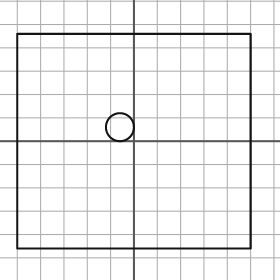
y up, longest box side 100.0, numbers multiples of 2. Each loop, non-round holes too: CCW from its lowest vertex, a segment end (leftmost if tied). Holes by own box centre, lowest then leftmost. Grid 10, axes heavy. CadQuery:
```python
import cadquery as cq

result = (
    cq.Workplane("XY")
    .moveTo(-50.0, -46.0)
    .lineTo(50.0, -46.0)
    .lineTo(50.0, 46.0)
    .lineTo(-50.0, 46.0)
    .close()
    .moveTo(-6.0, 6.0)
    .circle(6.0)
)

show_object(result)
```